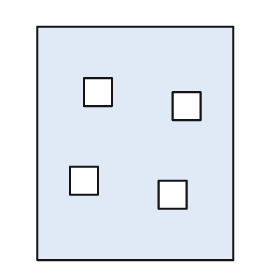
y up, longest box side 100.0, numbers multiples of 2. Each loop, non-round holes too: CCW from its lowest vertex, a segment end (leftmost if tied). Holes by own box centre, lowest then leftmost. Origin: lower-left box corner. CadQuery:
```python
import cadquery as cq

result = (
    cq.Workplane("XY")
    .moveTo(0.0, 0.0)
    .lineTo(84.0, 0.0)
    .lineTo(84.0, 100.0)
    .lineTo(0.0, 100.0)
    .close()
    .moveTo(52.0, 22.0)
    .lineTo(64.0, 22.0)
    .lineTo(64.0, 34.0)
    .lineTo(52.0, 34.0)
    .close()
    .moveTo(14.0, 28.0)
    .lineTo(26.0, 28.0)
    .lineTo(26.0, 40.0)
    .lineTo(14.0, 40.0)
    .close()
    .moveTo(58.0, 60.0)
    .lineTo(70.0, 60.0)
    .lineTo(70.0, 72.0)
    .lineTo(58.0, 72.0)
    .close()
    .moveTo(20.0, 66.0)
    .lineTo(32.0, 66.0)
    .lineTo(32.0, 78.0)
    .lineTo(20.0, 78.0)
    .close()
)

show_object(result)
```